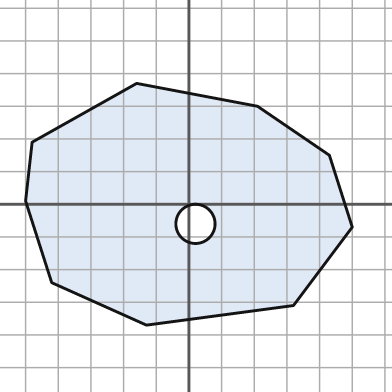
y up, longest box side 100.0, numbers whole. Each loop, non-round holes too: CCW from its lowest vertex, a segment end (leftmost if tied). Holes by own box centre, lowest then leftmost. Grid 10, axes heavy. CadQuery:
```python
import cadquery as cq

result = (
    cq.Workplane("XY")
    .moveTo(-13.0, -37.0)
    .lineTo(32.0, -31.0)
    .lineTo(50.0, -7.0)
    .lineTo(43.0, 15.0)
    .lineTo(21.0, 30.0)
    .lineTo(-16.0, 37.0)
    .lineTo(-48.0, 19.0)
    .lineTo(-50.0, 1.0)
    .lineTo(-42.0, -24.0)
    .close()
    .moveTo(2.0, -6.0)
    .circle(6.0)
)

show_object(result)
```